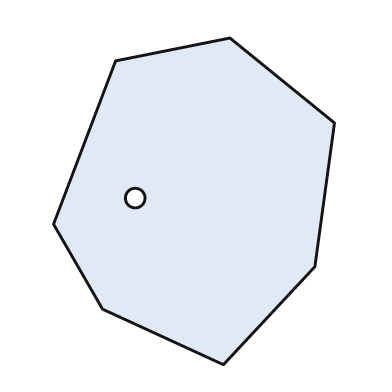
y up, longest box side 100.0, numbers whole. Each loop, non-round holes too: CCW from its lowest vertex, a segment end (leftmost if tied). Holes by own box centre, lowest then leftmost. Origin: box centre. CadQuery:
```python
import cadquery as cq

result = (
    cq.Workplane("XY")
    .moveTo(9.0, -50.0)
    .lineTo(37.0, -20.0)
    .lineTo(43.0, 24.0)
    .lineTo(11.0, 50.0)
    .lineTo(-24.0, 43.0)
    .lineTo(-43.0, -7.0)
    .lineTo(-28.0, -33.0)
    .close()
    .moveTo(-18.0, 1.0)
    .circle(3.0)
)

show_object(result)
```